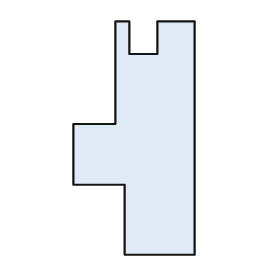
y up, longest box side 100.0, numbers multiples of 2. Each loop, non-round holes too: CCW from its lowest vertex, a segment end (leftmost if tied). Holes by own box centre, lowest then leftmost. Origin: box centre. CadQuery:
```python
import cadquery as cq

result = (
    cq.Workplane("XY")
    .moveTo(-4.0, -50.0)
    .lineTo(26.0, -50.0)
    .lineTo(26.0, 50.0)
    .lineTo(10.0, 50.0)
    .lineTo(10.0, 36.0)
    .lineTo(-2.0, 36.0)
    .lineTo(-2.0, 50.0)
    .lineTo(-8.0, 50.0)
    .lineTo(-8.0, 6.0)
    .lineTo(-26.0, 6.0)
    .lineTo(-26.0, -20.0)
    .lineTo(-4.0, -20.0)
    .close()
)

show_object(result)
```